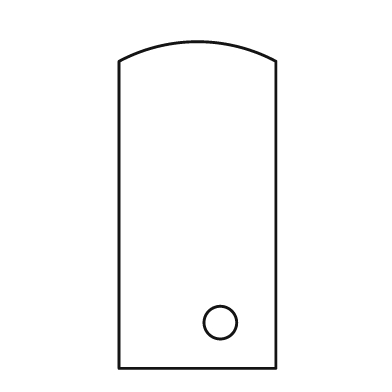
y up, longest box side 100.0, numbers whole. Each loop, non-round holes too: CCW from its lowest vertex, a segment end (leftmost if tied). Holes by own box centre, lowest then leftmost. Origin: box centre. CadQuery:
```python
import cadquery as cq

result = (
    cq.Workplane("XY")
    .moveTo(-24.0, -50.0)
    .lineTo(24.0, -50.0)
    .lineTo(24.0, 44.0)
    .threePointArc((0.0, 50.0), (-24.0, 44.0))
    .close()
    .moveTo(7.0, -36.0)
    .circle(5.0)
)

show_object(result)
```